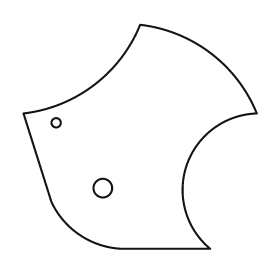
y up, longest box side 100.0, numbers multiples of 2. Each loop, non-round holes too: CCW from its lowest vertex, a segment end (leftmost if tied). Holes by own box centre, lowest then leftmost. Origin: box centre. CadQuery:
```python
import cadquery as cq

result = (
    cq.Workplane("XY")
    .moveTo(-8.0, -48.0)
    .lineTo(30.0, -48.0)
    .threePointArc((20.0, -12.0), (50.0, 10.0))
    .threePointArc((30.0, 36.0), (0.0, 48.0))
    .threePointArc((-20.0, 22.0), (-50.0, 10.0))
    .lineTo(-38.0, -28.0)
    .threePointArc((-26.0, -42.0), (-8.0, -48.0))
    .close()
    .moveTo(-16.0, -22.0)
    .circle(4.0)
    .moveTo(-36.0, 6.0)
    .circle(2.0)
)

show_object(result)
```